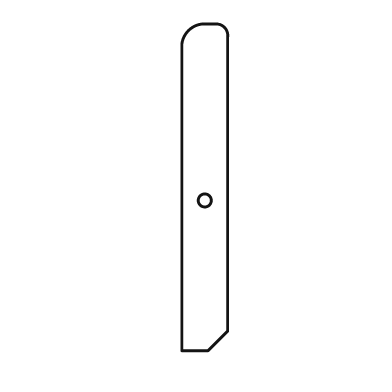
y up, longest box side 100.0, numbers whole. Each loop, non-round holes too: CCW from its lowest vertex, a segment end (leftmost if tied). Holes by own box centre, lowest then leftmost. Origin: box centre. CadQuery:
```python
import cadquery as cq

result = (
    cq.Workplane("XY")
    .moveTo(-7.0, -50.0)
    .lineTo(1.0, -50.0)
    .lineTo(7.0, -44.0)
    .lineTo(7.0, 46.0)
    .threePointArc((6.0, 49.0), (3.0, 50.0))
    .lineTo(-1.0, 50.0)
    .threePointArc((-5.0, 48.0), (-7.0, 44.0))
    .close()
    .moveTo(0.0, -4.0)
    .circle(2.0)
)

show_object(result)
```